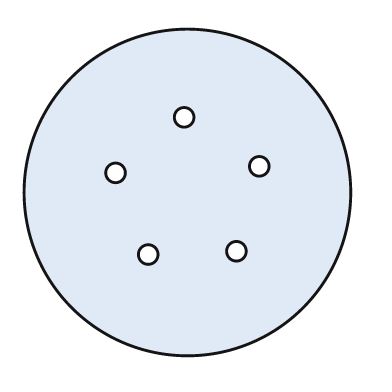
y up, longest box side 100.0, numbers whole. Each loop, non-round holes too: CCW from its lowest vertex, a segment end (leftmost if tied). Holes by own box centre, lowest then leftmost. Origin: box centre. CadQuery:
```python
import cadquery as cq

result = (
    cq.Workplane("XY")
    .moveTo(0.0, 0.0)
    .circle(50.0)
    .moveTo(-12.0, -19.0)
    .circle(3.0)
    .moveTo(15.0, -18.0)
    .circle(3.0)
    .moveTo(-22.0, 6.0)
    .circle(3.0)
    .moveTo(22.0, 8.0)
    .circle(3.0)
    .moveTo(-1.0, 23.0)
    .circle(3.0)
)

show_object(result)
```